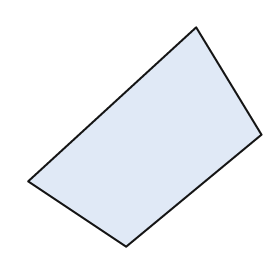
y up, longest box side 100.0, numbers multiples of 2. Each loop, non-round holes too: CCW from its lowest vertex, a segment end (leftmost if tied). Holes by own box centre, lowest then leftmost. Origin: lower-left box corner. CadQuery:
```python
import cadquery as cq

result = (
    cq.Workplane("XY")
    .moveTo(42.0, 0.0)
    .lineTo(100.0, 48.0)
    .lineTo(72.0, 94.0)
    .lineTo(0.0, 28.0)
    .close()
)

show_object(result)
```